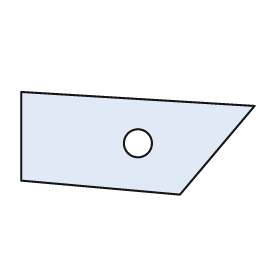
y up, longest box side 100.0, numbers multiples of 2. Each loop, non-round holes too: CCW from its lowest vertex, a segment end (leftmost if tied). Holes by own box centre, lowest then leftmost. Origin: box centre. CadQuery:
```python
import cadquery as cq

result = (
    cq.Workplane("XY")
    .moveTo(18.0, -22.0)
    .lineTo(50.0, 16.0)
    .lineTo(-50.0, 22.0)
    .lineTo(-50.0, -16.0)
    .close()
    .moveTo(0.0, 0.0)
    .circle(6.0)
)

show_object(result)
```